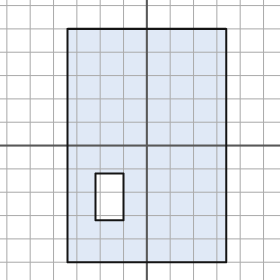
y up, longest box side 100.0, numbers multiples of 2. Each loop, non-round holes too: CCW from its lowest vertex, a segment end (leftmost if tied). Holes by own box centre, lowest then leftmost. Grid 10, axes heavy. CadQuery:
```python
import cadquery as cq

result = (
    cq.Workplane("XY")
    .moveTo(-34.0, -50.0)
    .lineTo(34.0, -50.0)
    .lineTo(34.0, 50.0)
    .lineTo(-34.0, 50.0)
    .close()
    .moveTo(-22.0, -32.0)
    .lineTo(-10.0, -32.0)
    .lineTo(-10.0, -12.0)
    .lineTo(-22.0, -12.0)
    .close()
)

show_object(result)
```